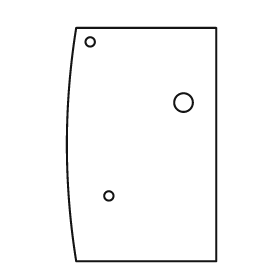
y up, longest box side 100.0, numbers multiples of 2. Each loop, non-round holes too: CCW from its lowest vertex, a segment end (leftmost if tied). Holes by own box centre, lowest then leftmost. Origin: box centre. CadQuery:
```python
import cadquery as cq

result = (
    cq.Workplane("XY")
    .moveTo(-28.0, -50.0)
    .lineTo(32.0, -50.0)
    .lineTo(32.0, 50.0)
    .lineTo(-28.0, 50.0)
    .threePointArc((-32.0, 0.0), (-28.0, -50.0))
    .close()
    .moveTo(-14.0, -22.0)
    .circle(2.0)
    .moveTo(18.0, 18.0)
    .circle(4.0)
    .moveTo(-22.0, 44.0)
    .circle(2.0)
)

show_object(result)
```